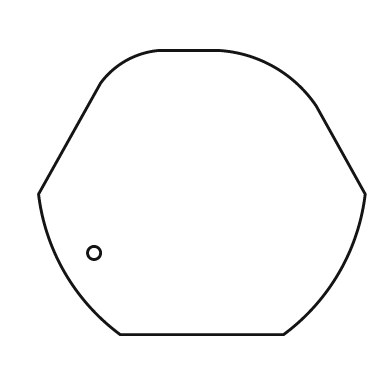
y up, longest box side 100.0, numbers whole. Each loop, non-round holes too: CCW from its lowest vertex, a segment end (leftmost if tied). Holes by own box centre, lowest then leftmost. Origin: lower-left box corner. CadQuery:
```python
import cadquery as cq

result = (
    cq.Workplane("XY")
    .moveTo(25.0, 0.0)
    .lineTo(75.0, 0.0)
    .threePointArc((92.0, 19.0), (100.0, 43.0))
    .lineTo(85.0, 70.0)
    .threePointArc((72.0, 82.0), (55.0, 87.0))
    .lineTo(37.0, 87.0)
    .threePointArc((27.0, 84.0), (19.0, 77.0))
    .lineTo(0.0, 43.0)
    .threePointArc((8.0, 19.0), (25.0, 0.0))
    .close()
    .moveTo(17.0, 25.0)
    .circle(2.0)
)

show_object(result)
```